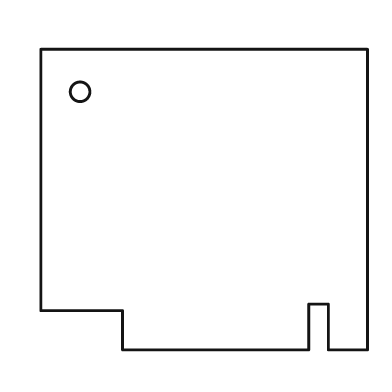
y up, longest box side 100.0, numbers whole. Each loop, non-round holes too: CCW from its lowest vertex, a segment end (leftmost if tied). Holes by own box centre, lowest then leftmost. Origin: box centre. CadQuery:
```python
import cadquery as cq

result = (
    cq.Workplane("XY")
    .moveTo(-25.0, -46.0)
    .lineTo(32.0, -46.0)
    .lineTo(32.0, -32.0)
    .lineTo(38.0, -32.0)
    .lineTo(38.0, -46.0)
    .lineTo(50.0, -46.0)
    .lineTo(50.0, 46.0)
    .lineTo(-50.0, 46.0)
    .lineTo(-50.0, -34.0)
    .lineTo(-25.0, -34.0)
    .close()
    .moveTo(-38.0, 33.0)
    .circle(3.0)
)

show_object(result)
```